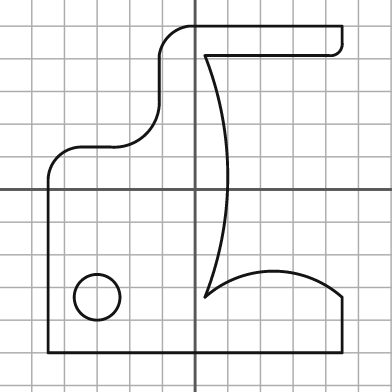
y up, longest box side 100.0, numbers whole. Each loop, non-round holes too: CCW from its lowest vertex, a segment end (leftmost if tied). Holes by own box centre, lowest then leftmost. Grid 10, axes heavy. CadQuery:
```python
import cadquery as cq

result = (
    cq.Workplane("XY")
    .moveTo(-45.0, -50.0)
    .lineTo(45.0, -50.0)
    .lineTo(45.0, -33.0)
    .threePointArc((24.0, -25.0), (3.0, -33.0))
    .threePointArc((10.0, 4.0), (3.0, 41.0))
    .lineTo(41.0, 41.0)
    .threePointArc((44.0, 42.0), (45.0, 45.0))
    .lineTo(45.0, 50.0)
    .lineTo(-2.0, 50.0)
    .threePointArc((-8.0, 47.0), (-11.0, 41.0))
    .lineTo(-11.0, 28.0)
    .threePointArc((-15.0, 17.0), (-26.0, 13.0))
    .lineTo(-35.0, 13.0)
    .threePointArc((-42.0, 10.0), (-45.0, 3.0))
    .close()
    .moveTo(-30.0, -33.0)
    .circle(7.0)
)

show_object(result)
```